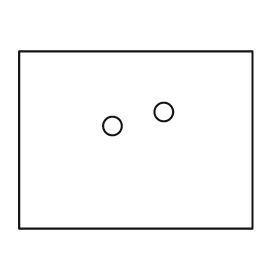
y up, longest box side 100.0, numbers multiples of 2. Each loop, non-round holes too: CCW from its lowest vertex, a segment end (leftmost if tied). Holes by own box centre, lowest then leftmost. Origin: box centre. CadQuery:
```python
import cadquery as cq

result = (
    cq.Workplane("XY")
    .moveTo(-50.0, -38.0)
    .lineTo(50.0, -38.0)
    .lineTo(50.0, 38.0)
    .lineTo(-50.0, 38.0)
    .close()
    .moveTo(-10.0, 6.0)
    .circle(4.0)
    .moveTo(12.0, 12.0)
    .circle(4.0)
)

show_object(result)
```